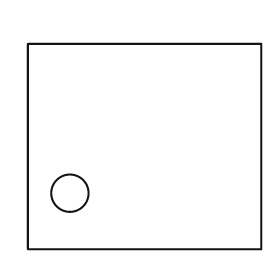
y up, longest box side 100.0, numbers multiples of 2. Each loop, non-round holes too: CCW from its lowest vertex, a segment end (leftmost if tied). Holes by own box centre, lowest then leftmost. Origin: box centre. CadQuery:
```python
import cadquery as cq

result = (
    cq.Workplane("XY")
    .moveTo(-50.0, -44.0)
    .lineTo(50.0, -44.0)
    .lineTo(50.0, 44.0)
    .lineTo(-50.0, 44.0)
    .close()
    .moveTo(-32.0, -20.0)
    .circle(8.0)
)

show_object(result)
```